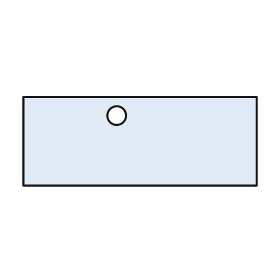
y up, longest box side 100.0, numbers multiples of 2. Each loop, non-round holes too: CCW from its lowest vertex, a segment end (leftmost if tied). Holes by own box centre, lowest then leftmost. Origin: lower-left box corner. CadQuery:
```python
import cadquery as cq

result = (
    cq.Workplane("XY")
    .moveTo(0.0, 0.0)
    .lineTo(100.0, 0.0)
    .lineTo(100.0, 38.0)
    .lineTo(0.0, 38.0)
    .close()
    .moveTo(40.0, 30.0)
    .circle(4.0)
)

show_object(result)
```